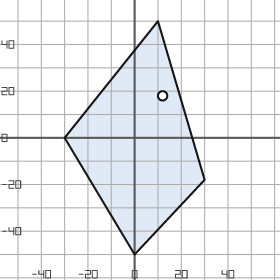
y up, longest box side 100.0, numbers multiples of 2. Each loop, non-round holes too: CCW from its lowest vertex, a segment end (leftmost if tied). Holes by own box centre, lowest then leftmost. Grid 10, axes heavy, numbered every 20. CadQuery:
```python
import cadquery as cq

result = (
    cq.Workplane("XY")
    .moveTo(0.0, -50.0)
    .lineTo(30.0, -18.0)
    .lineTo(10.0, 50.0)
    .lineTo(-30.0, 0.0)
    .close()
    .moveTo(12.0, 18.0)
    .circle(2.0)
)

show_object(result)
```